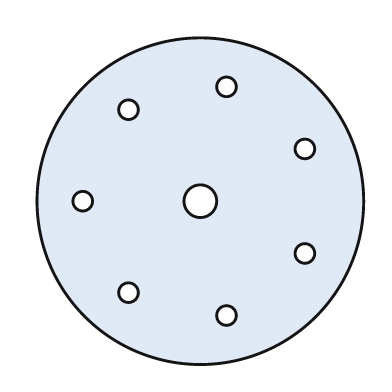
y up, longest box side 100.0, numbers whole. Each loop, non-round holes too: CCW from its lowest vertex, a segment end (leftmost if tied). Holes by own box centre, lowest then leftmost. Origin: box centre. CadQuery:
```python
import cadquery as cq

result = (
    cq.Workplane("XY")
    .moveTo(0.0, 0.0)
    .circle(50.0)
    .moveTo(8.0, -35.0)
    .circle(3.0)
    .moveTo(-22.0, -28.0)
    .circle(3.0)
    .moveTo(32.0, -16.0)
    .circle(3.0)
    .moveTo(-36.0, 0.0)
    .circle(3.0)
    .moveTo(0.0, 0.0)
    .circle(5.0)
    .moveTo(32.0, 16.0)
    .circle(3.0)
    .moveTo(-22.0, 28.0)
    .circle(3.0)
    .moveTo(8.0, 35.0)
    .circle(3.0)
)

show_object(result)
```